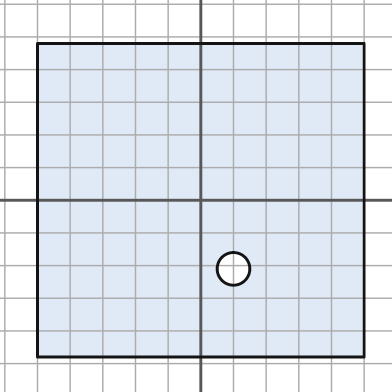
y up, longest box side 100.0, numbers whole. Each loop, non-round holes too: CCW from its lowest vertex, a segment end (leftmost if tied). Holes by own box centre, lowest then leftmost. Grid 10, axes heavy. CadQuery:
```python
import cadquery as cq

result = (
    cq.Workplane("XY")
    .moveTo(-50.0, -48.0)
    .lineTo(50.0, -48.0)
    .lineTo(50.0, 48.0)
    .lineTo(-50.0, 48.0)
    .close()
    .moveTo(10.0, -21.0)
    .circle(5.0)
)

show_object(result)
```